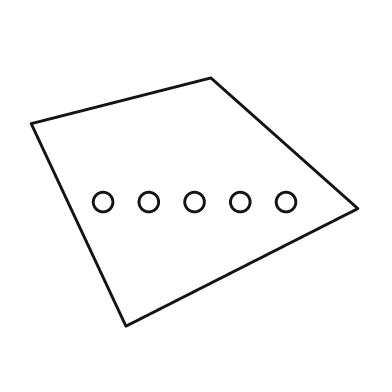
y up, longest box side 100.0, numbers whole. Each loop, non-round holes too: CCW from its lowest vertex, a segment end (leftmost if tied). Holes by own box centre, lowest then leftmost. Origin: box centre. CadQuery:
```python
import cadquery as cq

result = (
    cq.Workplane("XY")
    .moveTo(-21.0, -38.0)
    .lineTo(50.0, -2.0)
    .lineTo(5.0, 38.0)
    .lineTo(-50.0, 24.0)
    .close()
    .moveTo(-28.0, 0.0)
    .circle(3.0)
    .moveTo(-14.0, 0.0)
    .circle(3.0)
    .moveTo(0.0, 0.0)
    .circle(3.0)
    .moveTo(14.0, 0.0)
    .circle(3.0)
    .moveTo(28.0, 0.0)
    .circle(3.0)
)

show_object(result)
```